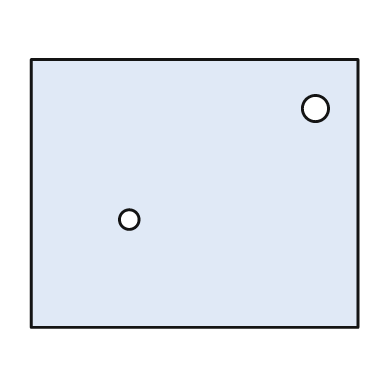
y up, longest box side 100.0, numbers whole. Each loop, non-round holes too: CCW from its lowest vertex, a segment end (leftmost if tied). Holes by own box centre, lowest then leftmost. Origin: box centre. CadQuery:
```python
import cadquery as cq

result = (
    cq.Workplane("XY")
    .moveTo(-50.0, -41.0)
    .lineTo(50.0, -41.0)
    .lineTo(50.0, 41.0)
    .lineTo(-50.0, 41.0)
    .close()
    .moveTo(-20.0, -8.0)
    .circle(3.0)
    .moveTo(37.0, 26.0)
    .circle(4.0)
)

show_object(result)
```